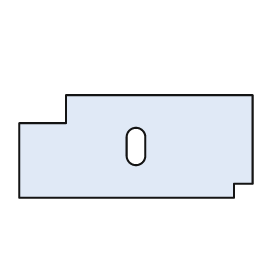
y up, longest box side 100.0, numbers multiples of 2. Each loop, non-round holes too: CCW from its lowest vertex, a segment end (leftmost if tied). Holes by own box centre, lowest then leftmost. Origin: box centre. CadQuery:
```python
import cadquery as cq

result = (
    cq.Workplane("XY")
    .moveTo(-50.0, -22.0)
    .lineTo(42.0, -22.0)
    .lineTo(42.0, -16.0)
    .lineTo(50.0, -16.0)
    .lineTo(50.0, 22.0)
    .lineTo(-30.0, 22.0)
    .lineTo(-30.0, 10.0)
    .lineTo(-50.0, 10.0)
    .close()
    .moveTo(-4.0, -4.0)
    .threePointArc((0.0, -8.0), (4.0, -4.0))
    .lineTo(4.0, 4.0)
    .threePointArc((0.0, 8.0), (-4.0, 4.0))
    .close()
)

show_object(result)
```